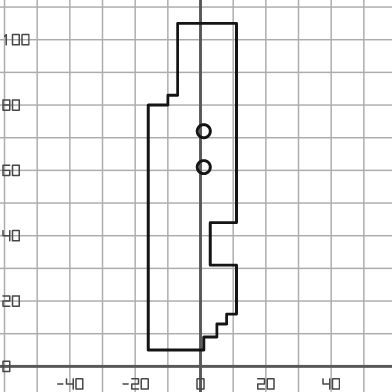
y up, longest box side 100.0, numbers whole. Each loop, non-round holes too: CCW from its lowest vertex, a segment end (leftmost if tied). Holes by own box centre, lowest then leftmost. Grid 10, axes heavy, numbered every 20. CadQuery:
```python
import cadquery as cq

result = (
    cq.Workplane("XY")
    .moveTo(-16.0, 5.0)
    .lineTo(1.0, 5.0)
    .lineTo(1.0, 9.0)
    .lineTo(5.0, 9.0)
    .lineTo(5.0, 13.0)
    .lineTo(8.0, 13.0)
    .lineTo(8.0, 16.0)
    .lineTo(11.0, 16.0)
    .lineTo(11.0, 31.0)
    .lineTo(3.0, 31.0)
    .lineTo(3.0, 44.0)
    .lineTo(11.0, 44.0)
    .lineTo(11.0, 105.0)
    .lineTo(-7.0, 105.0)
    .lineTo(-7.0, 83.0)
    .lineTo(-10.0, 83.0)
    .lineTo(-10.0, 80.0)
    .lineTo(-16.0, 80.0)
    .close()
    .moveTo(1.0, 61.0)
    .circle(2.0)
    .moveTo(1.0, 72.0)
    .circle(2.0)
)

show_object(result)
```